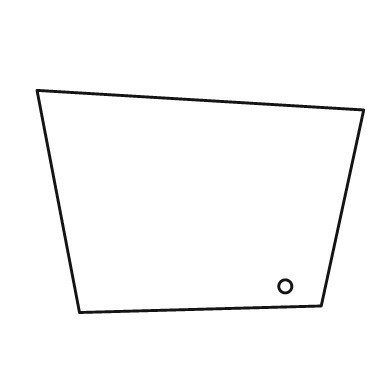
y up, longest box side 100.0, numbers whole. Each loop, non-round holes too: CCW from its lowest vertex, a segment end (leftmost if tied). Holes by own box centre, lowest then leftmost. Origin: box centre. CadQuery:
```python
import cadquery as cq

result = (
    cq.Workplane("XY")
    .moveTo(-37.0, -34.0)
    .lineTo(37.0, -32.0)
    .lineTo(50.0, 28.0)
    .lineTo(-50.0, 34.0)
    .close()
    .moveTo(26.0, -26.0)
    .circle(2.0)
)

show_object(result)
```